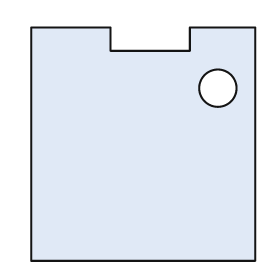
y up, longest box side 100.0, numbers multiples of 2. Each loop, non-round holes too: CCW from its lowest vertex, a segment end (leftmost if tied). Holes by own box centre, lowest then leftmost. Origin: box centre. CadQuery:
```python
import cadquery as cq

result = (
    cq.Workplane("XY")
    .moveTo(-48.0, -50.0)
    .lineTo(48.0, -50.0)
    .lineTo(48.0, 50.0)
    .lineTo(20.0, 50.0)
    .lineTo(20.0, 40.0)
    .lineTo(-14.0, 40.0)
    .lineTo(-14.0, 50.0)
    .lineTo(-48.0, 50.0)
    .close()
    .moveTo(32.0, 24.0)
    .circle(8.0)
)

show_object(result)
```